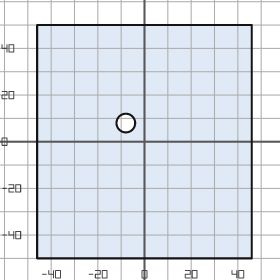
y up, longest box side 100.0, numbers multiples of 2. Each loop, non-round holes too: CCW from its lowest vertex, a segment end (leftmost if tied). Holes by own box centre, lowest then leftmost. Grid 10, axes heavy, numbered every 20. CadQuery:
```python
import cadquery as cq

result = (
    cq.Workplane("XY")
    .moveTo(-46.0, -50.0)
    .lineTo(46.0, -50.0)
    .lineTo(46.0, 50.0)
    .lineTo(-46.0, 50.0)
    .close()
    .moveTo(-8.0, 8.0)
    .circle(4.0)
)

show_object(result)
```